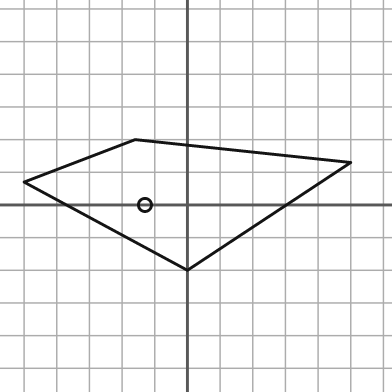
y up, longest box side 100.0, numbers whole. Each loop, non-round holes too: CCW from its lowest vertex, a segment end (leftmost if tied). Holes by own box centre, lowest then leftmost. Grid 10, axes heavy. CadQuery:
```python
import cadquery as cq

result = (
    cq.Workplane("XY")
    .moveTo(0.0, -20.0)
    .lineTo(50.0, 13.0)
    .lineTo(-16.0, 20.0)
    .lineTo(-50.0, 7.0)
    .close()
    .moveTo(-13.0, 0.0)
    .circle(2.0)
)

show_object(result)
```